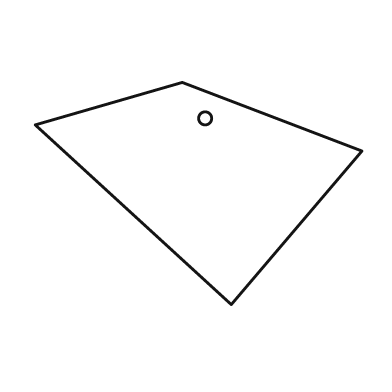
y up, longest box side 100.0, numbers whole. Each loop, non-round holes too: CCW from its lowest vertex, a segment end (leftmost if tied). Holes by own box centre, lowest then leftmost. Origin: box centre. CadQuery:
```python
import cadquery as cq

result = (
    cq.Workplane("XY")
    .moveTo(10.0, -34.0)
    .lineTo(50.0, 13.0)
    .lineTo(-5.0, 34.0)
    .lineTo(-50.0, 21.0)
    .close()
    .moveTo(2.0, 23.0)
    .circle(2.0)
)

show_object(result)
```